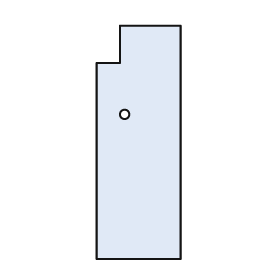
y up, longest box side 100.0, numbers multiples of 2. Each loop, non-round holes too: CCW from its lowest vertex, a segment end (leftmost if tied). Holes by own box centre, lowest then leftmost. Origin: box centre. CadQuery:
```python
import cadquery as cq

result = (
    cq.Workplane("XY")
    .moveTo(-18.0, -50.0)
    .lineTo(18.0, -50.0)
    .lineTo(18.0, 50.0)
    .lineTo(-8.0, 50.0)
    .lineTo(-8.0, 34.0)
    .lineTo(-18.0, 34.0)
    .close()
    .moveTo(-6.0, 12.0)
    .circle(2.0)
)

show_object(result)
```